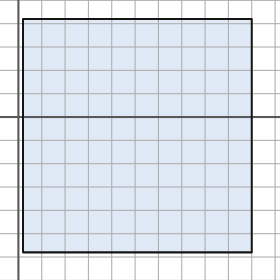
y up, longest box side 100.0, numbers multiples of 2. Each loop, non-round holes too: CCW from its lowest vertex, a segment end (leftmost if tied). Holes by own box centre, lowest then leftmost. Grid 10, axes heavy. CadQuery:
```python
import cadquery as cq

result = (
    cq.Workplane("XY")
    .moveTo(2.0, -58.0)
    .lineTo(100.0, -58.0)
    .lineTo(100.0, 42.0)
    .lineTo(2.0, 42.0)
    .close()
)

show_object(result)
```